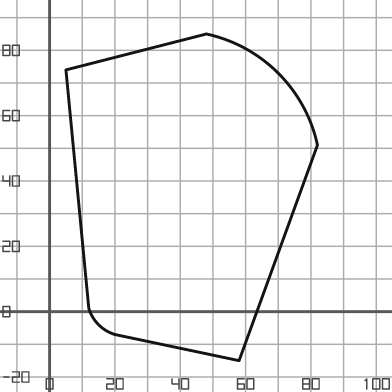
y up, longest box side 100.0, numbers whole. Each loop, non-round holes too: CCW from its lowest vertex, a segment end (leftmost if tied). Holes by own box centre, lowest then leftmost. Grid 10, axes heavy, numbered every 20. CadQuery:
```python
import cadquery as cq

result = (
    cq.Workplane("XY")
    .moveTo(58.0, -15.0)
    .lineTo(82.0, 51.0)
    .threePointArc((70.0, 73.0), (48.0, 85.0))
    .lineTo(5.0, 74.0)
    .lineTo(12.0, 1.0)
    .threePointArc((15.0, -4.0), (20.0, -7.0))
    .close()
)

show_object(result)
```